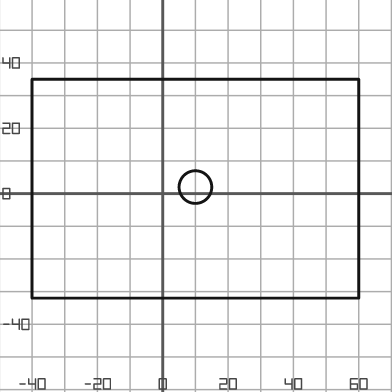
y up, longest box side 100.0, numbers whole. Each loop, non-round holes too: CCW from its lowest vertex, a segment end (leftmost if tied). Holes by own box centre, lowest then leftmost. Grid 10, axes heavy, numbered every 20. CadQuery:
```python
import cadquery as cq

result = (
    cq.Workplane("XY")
    .moveTo(-40.0, -32.0)
    .lineTo(60.0, -32.0)
    .lineTo(60.0, 35.0)
    .lineTo(-40.0, 35.0)
    .close()
    .moveTo(10.0, 2.0)
    .circle(5.0)
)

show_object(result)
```